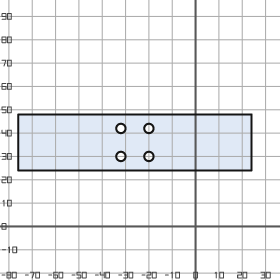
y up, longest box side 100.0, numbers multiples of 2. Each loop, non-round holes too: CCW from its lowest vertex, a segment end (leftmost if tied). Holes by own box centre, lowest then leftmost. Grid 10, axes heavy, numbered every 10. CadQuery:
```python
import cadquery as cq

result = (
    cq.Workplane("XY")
    .moveTo(-76.0, 24.0)
    .lineTo(24.0, 24.0)
    .lineTo(24.0, 48.0)
    .lineTo(-76.0, 48.0)
    .close()
    .moveTo(-32.0, 30.0)
    .circle(2.0)
    .moveTo(-20.0, 30.0)
    .circle(2.0)
    .moveTo(-32.0, 42.0)
    .circle(2.0)
    .moveTo(-20.0, 42.0)
    .circle(2.0)
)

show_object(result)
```